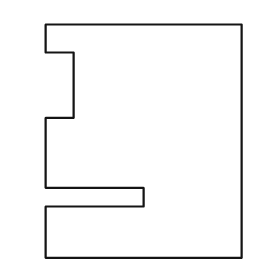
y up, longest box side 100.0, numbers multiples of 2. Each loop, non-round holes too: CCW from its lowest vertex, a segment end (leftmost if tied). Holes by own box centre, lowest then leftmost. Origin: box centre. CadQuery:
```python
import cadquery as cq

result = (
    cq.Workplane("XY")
    .moveTo(-42.0, -50.0)
    .lineTo(42.0, -50.0)
    .lineTo(42.0, 50.0)
    .lineTo(-42.0, 50.0)
    .lineTo(-42.0, 38.0)
    .lineTo(-30.0, 38.0)
    .lineTo(-30.0, 10.0)
    .lineTo(-42.0, 10.0)
    .lineTo(-42.0, -20.0)
    .lineTo(0.0, -20.0)
    .lineTo(0.0, -28.0)
    .lineTo(-42.0, -28.0)
    .close()
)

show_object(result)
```